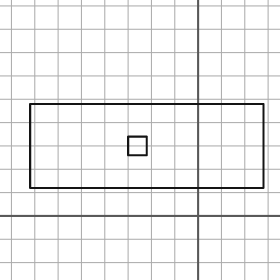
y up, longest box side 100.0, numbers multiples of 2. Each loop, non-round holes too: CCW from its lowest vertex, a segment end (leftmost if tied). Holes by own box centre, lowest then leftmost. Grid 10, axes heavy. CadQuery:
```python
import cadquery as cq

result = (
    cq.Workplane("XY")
    .moveTo(-72.0, 12.0)
    .lineTo(28.0, 12.0)
    .lineTo(28.0, 48.0)
    .lineTo(-72.0, 48.0)
    .close()
    .moveTo(-30.0, 26.0)
    .lineTo(-22.0, 26.0)
    .lineTo(-22.0, 34.0)
    .lineTo(-30.0, 34.0)
    .close()
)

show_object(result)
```